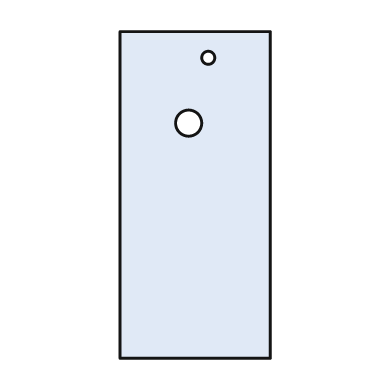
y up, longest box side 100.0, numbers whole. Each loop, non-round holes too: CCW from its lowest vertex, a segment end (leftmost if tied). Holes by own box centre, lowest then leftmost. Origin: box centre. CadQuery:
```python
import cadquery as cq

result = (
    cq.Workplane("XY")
    .moveTo(-23.0, -50.0)
    .lineTo(23.0, -50.0)
    .lineTo(23.0, 50.0)
    .lineTo(-23.0, 50.0)
    .close()
    .moveTo(-2.0, 22.0)
    .circle(4.0)
    .moveTo(4.0, 42.0)
    .circle(2.0)
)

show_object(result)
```